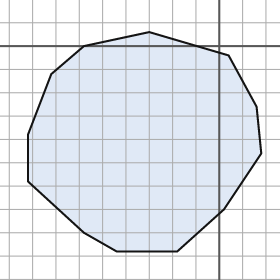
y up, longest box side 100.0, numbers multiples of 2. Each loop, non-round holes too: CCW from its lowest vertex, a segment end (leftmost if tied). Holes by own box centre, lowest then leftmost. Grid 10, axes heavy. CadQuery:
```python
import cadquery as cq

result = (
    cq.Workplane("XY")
    .moveTo(-44.0, -88.0)
    .lineTo(-18.0, -88.0)
    .lineTo(2.0, -70.0)
    .lineTo(18.0, -46.0)
    .lineTo(16.0, -26.0)
    .lineTo(4.0, -4.0)
    .lineTo(-30.0, 6.0)
    .lineTo(-58.0, 0.0)
    .lineTo(-72.0, -12.0)
    .lineTo(-82.0, -38.0)
    .lineTo(-82.0, -58.0)
    .lineTo(-58.0, -80.0)
    .close()
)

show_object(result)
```